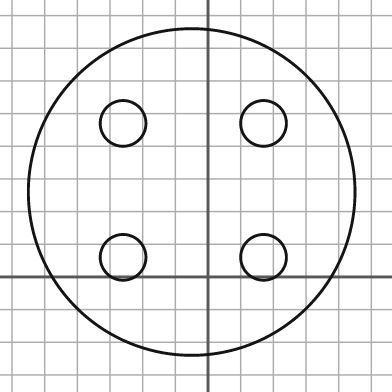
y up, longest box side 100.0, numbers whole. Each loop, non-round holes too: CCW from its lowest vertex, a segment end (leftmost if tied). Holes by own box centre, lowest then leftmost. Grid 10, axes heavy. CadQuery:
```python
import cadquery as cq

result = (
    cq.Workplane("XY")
    .moveTo(-5.0, 26.0)
    .circle(50.0)
    .moveTo(-26.0, 6.0)
    .circle(7.0)
    .moveTo(17.0, 6.0)
    .circle(7.0)
    .moveTo(-26.0, 47.0)
    .circle(7.0)
    .moveTo(17.0, 47.0)
    .circle(7.0)
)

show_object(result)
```